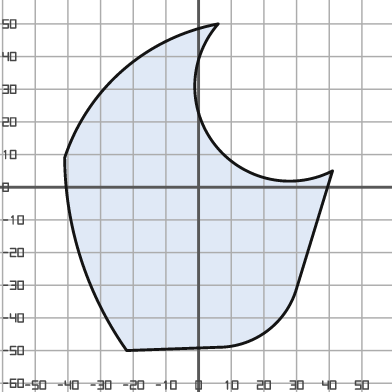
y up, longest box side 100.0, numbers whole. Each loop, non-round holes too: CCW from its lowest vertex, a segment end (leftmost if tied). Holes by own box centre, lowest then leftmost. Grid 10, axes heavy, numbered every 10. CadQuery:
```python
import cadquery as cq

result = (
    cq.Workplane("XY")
    .moveTo(-22.0, -50.0)
    .lineTo(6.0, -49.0)
    .threePointArc((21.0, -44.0), (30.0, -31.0))
    .lineTo(41.0, 5.0)
    .threePointArc((5.0, 13.0), (6.0, 50.0))
    .threePointArc((-23.0, 36.0), (-41.0, 9.0))
    .threePointArc((-36.0, -22.0), (-22.0, -50.0))
    .close()
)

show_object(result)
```